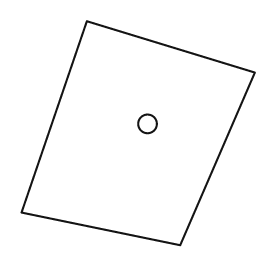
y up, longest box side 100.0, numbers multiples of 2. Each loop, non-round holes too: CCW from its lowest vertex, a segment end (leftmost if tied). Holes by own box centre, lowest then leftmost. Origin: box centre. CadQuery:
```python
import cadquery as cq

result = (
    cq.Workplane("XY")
    .moveTo(18.0, -48.0)
    .lineTo(50.0, 26.0)
    .lineTo(-22.0, 48.0)
    .lineTo(-50.0, -34.0)
    .close()
    .moveTo(4.0, 4.0)
    .circle(4.0)
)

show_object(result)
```